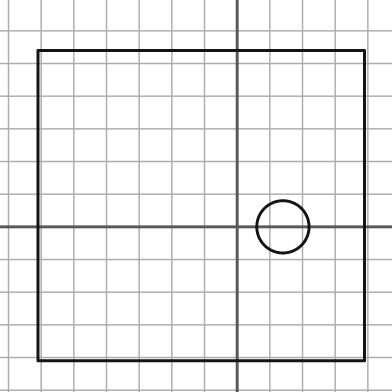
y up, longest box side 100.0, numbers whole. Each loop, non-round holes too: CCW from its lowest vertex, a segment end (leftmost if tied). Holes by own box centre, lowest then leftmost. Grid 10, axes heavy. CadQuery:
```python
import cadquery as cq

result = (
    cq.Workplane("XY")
    .moveTo(-61.0, -41.0)
    .lineTo(39.0, -41.0)
    .lineTo(39.0, 54.0)
    .lineTo(-61.0, 54.0)
    .close()
    .moveTo(14.0, 0.0)
    .circle(8.0)
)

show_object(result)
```